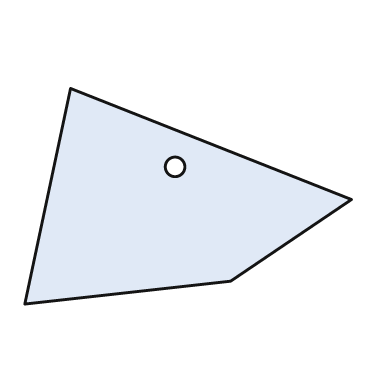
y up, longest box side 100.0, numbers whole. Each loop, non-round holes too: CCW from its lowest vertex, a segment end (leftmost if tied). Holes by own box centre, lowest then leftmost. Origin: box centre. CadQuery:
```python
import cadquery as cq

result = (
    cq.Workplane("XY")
    .moveTo(-50.0, -33.0)
    .lineTo(13.0, -26.0)
    .lineTo(50.0, -1.0)
    .lineTo(-36.0, 33.0)
    .close()
    .moveTo(-4.0, 9.0)
    .circle(3.0)
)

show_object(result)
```